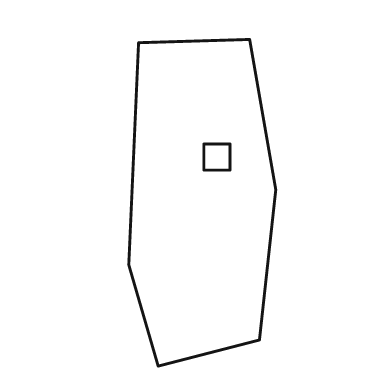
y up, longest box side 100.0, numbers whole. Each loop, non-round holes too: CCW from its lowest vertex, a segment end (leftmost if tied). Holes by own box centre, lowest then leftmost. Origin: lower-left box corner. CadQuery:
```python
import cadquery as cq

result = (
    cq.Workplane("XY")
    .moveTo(9.0, 0.0)
    .lineTo(40.0, 8.0)
    .lineTo(45.0, 54.0)
    .lineTo(37.0, 100.0)
    .lineTo(3.0, 99.0)
    .lineTo(0.0, 31.0)
    .close()
    .moveTo(23.0, 60.0)
    .lineTo(31.0, 60.0)
    .lineTo(31.0, 68.0)
    .lineTo(23.0, 68.0)
    .close()
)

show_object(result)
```